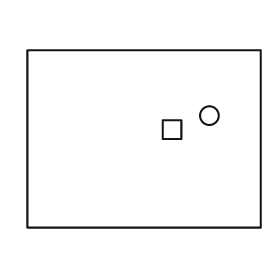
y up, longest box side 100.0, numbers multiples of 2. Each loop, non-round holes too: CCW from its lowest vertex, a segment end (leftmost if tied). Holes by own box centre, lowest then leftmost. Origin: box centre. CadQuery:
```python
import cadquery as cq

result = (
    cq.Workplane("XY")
    .moveTo(-50.0, -38.0)
    .lineTo(50.0, -38.0)
    .lineTo(50.0, 38.0)
    .lineTo(-50.0, 38.0)
    .close()
    .moveTo(8.0, 0.0)
    .lineTo(16.0, 0.0)
    .lineTo(16.0, 8.0)
    .lineTo(8.0, 8.0)
    .close()
    .moveTo(28.0, 10.0)
    .circle(4.0)
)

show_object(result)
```